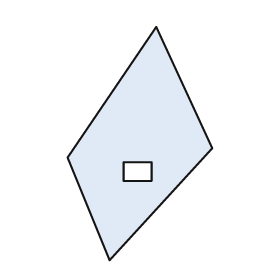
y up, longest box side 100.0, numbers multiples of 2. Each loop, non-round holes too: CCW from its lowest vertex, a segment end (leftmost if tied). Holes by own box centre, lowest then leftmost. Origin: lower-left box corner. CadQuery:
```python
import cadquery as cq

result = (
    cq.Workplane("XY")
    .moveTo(18.0, 0.0)
    .lineTo(62.0, 48.0)
    .lineTo(38.0, 100.0)
    .lineTo(0.0, 44.0)
    .close()
    .moveTo(24.0, 34.0)
    .lineTo(36.0, 34.0)
    .lineTo(36.0, 42.0)
    .lineTo(24.0, 42.0)
    .close()
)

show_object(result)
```